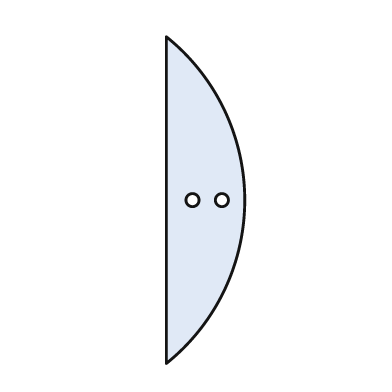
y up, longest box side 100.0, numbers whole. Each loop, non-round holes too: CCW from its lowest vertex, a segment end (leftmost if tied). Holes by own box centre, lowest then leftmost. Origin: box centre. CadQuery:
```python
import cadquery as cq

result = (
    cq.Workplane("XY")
    .moveTo(-12.0, -50.0)
    .threePointArc((12.0, 0.0), (-12.0, 50.0))
    .close()
    .moveTo(-4.0, 0.0)
    .circle(2.0)
    .moveTo(5.0, 0.0)
    .circle(2.0)
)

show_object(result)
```